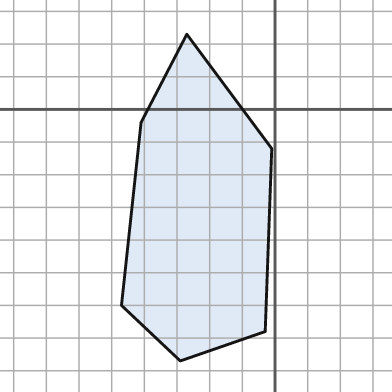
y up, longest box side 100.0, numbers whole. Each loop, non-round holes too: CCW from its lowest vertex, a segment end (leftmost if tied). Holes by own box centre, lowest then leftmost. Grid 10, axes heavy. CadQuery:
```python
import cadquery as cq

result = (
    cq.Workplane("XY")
    .moveTo(-29.0, -77.0)
    .lineTo(-3.0, -68.0)
    .lineTo(-1.0, -12.0)
    .lineTo(-27.0, 23.0)
    .lineTo(-41.0, -4.0)
    .lineTo(-47.0, -60.0)
    .close()
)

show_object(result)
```